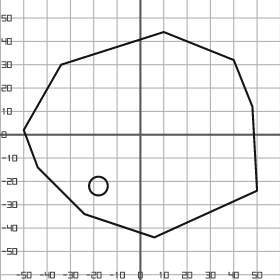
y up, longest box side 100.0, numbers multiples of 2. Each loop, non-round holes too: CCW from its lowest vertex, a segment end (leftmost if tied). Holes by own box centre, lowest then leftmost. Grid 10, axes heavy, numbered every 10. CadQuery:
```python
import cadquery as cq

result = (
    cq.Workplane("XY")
    .moveTo(6.0, -44.0)
    .lineTo(50.0, -24.0)
    .lineTo(48.0, 12.0)
    .lineTo(40.0, 32.0)
    .lineTo(10.0, 44.0)
    .lineTo(-34.0, 30.0)
    .lineTo(-50.0, 2.0)
    .lineTo(-44.0, -14.0)
    .lineTo(-24.0, -34.0)
    .close()
    .moveTo(-18.0, -22.0)
    .circle(4.0)
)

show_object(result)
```